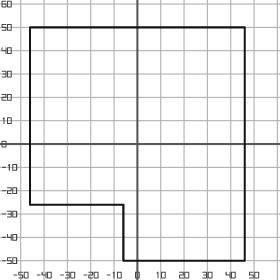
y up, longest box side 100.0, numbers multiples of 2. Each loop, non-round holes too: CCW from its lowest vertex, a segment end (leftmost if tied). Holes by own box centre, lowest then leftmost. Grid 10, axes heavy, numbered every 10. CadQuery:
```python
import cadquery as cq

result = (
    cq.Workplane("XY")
    .moveTo(-6.0, -50.0)
    .lineTo(46.0, -50.0)
    .lineTo(46.0, 50.0)
    .lineTo(-46.0, 50.0)
    .lineTo(-46.0, -26.0)
    .lineTo(-6.0, -26.0)
    .close()
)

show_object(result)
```